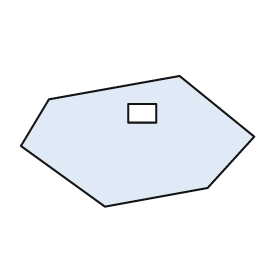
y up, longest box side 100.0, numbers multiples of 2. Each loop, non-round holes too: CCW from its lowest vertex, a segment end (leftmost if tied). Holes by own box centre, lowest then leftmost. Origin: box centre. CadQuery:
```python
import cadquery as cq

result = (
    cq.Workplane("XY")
    .moveTo(-14.0, -28.0)
    .lineTo(30.0, -20.0)
    .lineTo(50.0, 2.0)
    .lineTo(18.0, 28.0)
    .lineTo(-38.0, 18.0)
    .lineTo(-50.0, -2.0)
    .close()
    .moveTo(-4.0, 8.0)
    .lineTo(8.0, 8.0)
    .lineTo(8.0, 16.0)
    .lineTo(-4.0, 16.0)
    .close()
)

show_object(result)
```